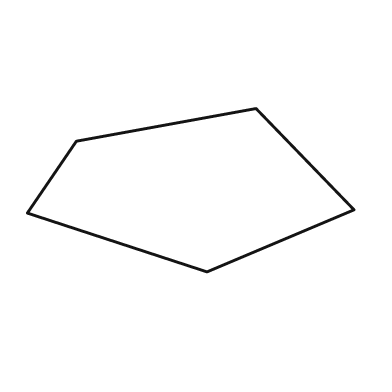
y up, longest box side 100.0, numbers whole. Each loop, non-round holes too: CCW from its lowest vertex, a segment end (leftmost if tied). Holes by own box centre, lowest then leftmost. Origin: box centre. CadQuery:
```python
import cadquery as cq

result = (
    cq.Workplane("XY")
    .moveTo(5.0, -25.0)
    .lineTo(50.0, -6.0)
    .lineTo(20.0, 25.0)
    .lineTo(-35.0, 15.0)
    .lineTo(-50.0, -7.0)
    .close()
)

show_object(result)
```